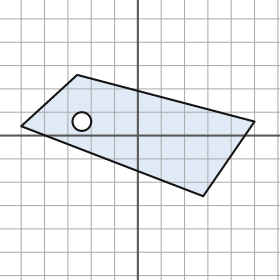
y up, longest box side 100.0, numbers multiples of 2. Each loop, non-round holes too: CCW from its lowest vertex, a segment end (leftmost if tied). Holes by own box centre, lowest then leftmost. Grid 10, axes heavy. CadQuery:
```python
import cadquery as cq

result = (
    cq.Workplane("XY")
    .moveTo(28.0, -26.0)
    .lineTo(50.0, 6.0)
    .lineTo(-26.0, 26.0)
    .lineTo(-50.0, 4.0)
    .close()
    .moveTo(-24.0, 6.0)
    .circle(4.0)
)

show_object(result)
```